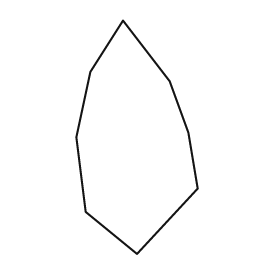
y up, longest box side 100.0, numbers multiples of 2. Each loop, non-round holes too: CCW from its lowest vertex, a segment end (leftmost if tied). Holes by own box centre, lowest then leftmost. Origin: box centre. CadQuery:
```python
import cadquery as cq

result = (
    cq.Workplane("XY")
    .moveTo(0.0, -50.0)
    .lineTo(26.0, -22.0)
    .lineTo(22.0, 2.0)
    .lineTo(14.0, 24.0)
    .lineTo(-6.0, 50.0)
    .lineTo(-20.0, 28.0)
    .lineTo(-26.0, 0.0)
    .lineTo(-22.0, -32.0)
    .close()
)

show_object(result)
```